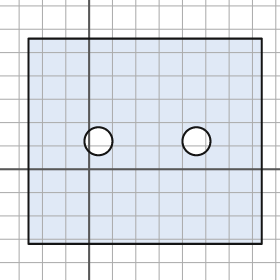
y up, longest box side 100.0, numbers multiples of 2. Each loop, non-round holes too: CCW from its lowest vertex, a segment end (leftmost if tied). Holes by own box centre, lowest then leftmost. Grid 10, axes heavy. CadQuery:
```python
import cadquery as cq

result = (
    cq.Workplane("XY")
    .moveTo(-26.0, -32.0)
    .lineTo(74.0, -32.0)
    .lineTo(74.0, 56.0)
    .lineTo(-26.0, 56.0)
    .close()
    .moveTo(4.0, 12.0)
    .circle(6.0)
    .moveTo(46.0, 12.0)
    .circle(6.0)
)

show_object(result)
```